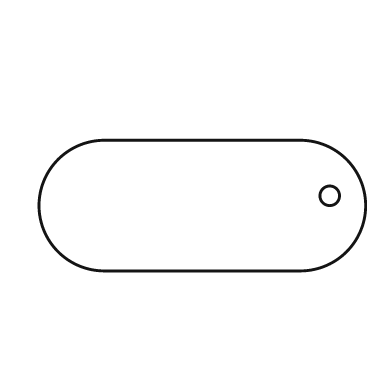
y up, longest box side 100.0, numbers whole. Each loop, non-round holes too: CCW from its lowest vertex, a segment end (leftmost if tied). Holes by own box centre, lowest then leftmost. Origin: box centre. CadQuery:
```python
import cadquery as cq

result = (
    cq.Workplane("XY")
    .moveTo(-30.0, -20.0)
    .lineTo(30.0, -20.0)
    .threePointArc((50.0, 0.0), (30.0, 20.0))
    .lineTo(-30.0, 20.0)
    .threePointArc((-50.0, 0.0), (-30.0, -20.0))
    .close()
    .moveTo(39.0, 3.0)
    .circle(3.0)
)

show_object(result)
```